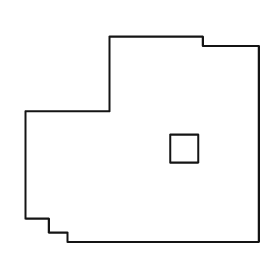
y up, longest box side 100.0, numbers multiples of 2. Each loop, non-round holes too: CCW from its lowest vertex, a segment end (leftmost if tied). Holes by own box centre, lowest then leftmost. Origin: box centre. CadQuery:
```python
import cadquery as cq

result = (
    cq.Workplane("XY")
    .moveTo(-32.0, -44.0)
    .lineTo(50.0, -44.0)
    .lineTo(50.0, 40.0)
    .lineTo(26.0, 40.0)
    .lineTo(26.0, 44.0)
    .lineTo(-14.0, 44.0)
    .lineTo(-14.0, 12.0)
    .lineTo(-50.0, 12.0)
    .lineTo(-50.0, -34.0)
    .lineTo(-40.0, -34.0)
    .lineTo(-40.0, -40.0)
    .lineTo(-32.0, -40.0)
    .close()
    .moveTo(12.0, -10.0)
    .lineTo(24.0, -10.0)
    .lineTo(24.0, 2.0)
    .lineTo(12.0, 2.0)
    .close()
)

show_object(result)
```